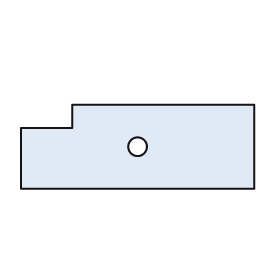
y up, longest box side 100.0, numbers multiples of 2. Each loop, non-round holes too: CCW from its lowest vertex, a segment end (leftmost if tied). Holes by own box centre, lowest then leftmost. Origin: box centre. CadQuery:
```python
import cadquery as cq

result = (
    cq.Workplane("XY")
    .moveTo(-50.0, -18.0)
    .lineTo(50.0, -18.0)
    .lineTo(50.0, 18.0)
    .lineTo(-28.0, 18.0)
    .lineTo(-28.0, 8.0)
    .lineTo(-50.0, 8.0)
    .close()
    .moveTo(0.0, 0.0)
    .circle(4.0)
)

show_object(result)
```